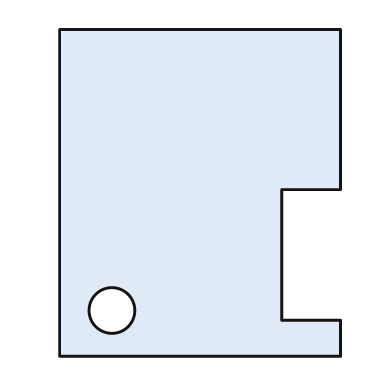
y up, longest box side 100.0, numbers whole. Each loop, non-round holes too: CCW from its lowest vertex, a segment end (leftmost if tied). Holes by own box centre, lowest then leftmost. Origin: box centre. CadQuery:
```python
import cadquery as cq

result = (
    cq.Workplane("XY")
    .moveTo(-43.0, -50.0)
    .lineTo(43.0, -50.0)
    .lineTo(43.0, -39.0)
    .lineTo(25.0, -39.0)
    .lineTo(25.0, 1.0)
    .lineTo(43.0, 1.0)
    .lineTo(43.0, 50.0)
    .lineTo(-43.0, 50.0)
    .close()
    .moveTo(-27.0, -36.0)
    .circle(7.0)
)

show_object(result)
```